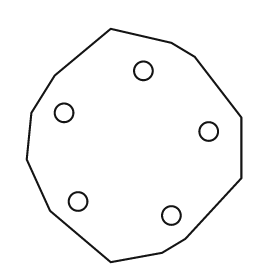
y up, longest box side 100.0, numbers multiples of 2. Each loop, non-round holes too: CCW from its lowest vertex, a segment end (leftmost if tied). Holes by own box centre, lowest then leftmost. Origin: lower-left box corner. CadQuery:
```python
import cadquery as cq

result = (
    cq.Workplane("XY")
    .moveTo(36.0, 0.0)
    .lineTo(58.0, 4.0)
    .lineTo(68.0, 10.0)
    .lineTo(92.0, 36.0)
    .lineTo(92.0, 62.0)
    .lineTo(72.0, 88.0)
    .lineTo(62.0, 94.0)
    .lineTo(36.0, 100.0)
    .lineTo(12.0, 80.0)
    .lineTo(2.0, 64.0)
    .lineTo(0.0, 44.0)
    .lineTo(10.0, 22.0)
    .close()
    .moveTo(62.0, 20.0)
    .circle(4.0)
    .moveTo(22.0, 26.0)
    .circle(4.0)
    .moveTo(78.0, 56.0)
    .circle(4.0)
    .moveTo(16.0, 64.0)
    .circle(4.0)
    .moveTo(50.0, 82.0)
    .circle(4.0)
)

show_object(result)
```